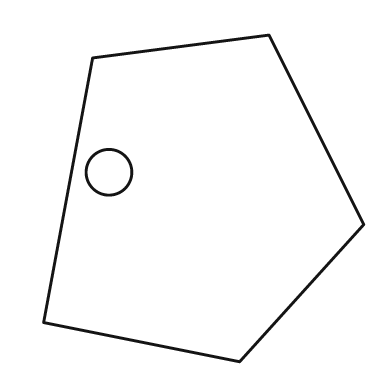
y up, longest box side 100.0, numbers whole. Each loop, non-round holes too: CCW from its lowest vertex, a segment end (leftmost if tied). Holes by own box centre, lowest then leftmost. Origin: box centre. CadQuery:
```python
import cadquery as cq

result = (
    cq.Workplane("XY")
    .moveTo(11.0, -50.0)
    .lineTo(49.0, -8.0)
    .lineTo(20.0, 50.0)
    .lineTo(-34.0, 43.0)
    .lineTo(-49.0, -38.0)
    .close()
    .moveTo(-29.0, 8.0)
    .circle(7.0)
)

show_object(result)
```